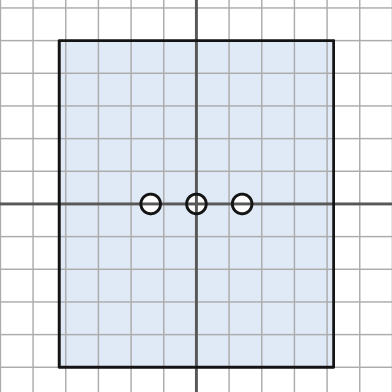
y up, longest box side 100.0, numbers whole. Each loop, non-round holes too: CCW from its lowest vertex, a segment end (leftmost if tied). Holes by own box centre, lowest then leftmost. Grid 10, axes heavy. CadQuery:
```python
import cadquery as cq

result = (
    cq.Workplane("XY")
    .moveTo(-42.0, -50.0)
    .lineTo(42.0, -50.0)
    .lineTo(42.0, 50.0)
    .lineTo(-42.0, 50.0)
    .close()
    .moveTo(-14.0, 0.0)
    .circle(3.0)
    .moveTo(0.0, 0.0)
    .circle(3.0)
    .moveTo(14.0, 0.0)
    .circle(3.0)
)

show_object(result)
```